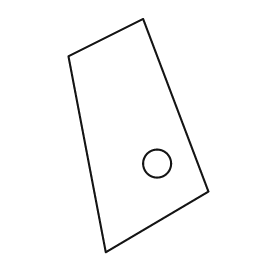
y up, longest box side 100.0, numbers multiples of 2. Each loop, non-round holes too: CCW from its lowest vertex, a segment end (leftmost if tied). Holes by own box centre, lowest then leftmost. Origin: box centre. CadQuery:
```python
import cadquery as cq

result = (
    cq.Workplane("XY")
    .moveTo(-14.0, -50.0)
    .lineTo(30.0, -24.0)
    .lineTo(2.0, 50.0)
    .lineTo(-30.0, 34.0)
    .close()
    .moveTo(8.0, -12.0)
    .circle(6.0)
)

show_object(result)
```